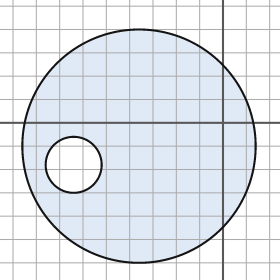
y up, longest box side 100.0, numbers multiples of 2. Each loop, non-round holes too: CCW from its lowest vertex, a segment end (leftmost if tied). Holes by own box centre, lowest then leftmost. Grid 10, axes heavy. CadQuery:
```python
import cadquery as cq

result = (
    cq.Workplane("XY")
    .moveTo(-36.0, -10.0)
    .circle(50.0)
    .moveTo(-64.0, -18.0)
    .circle(12.0)
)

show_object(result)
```